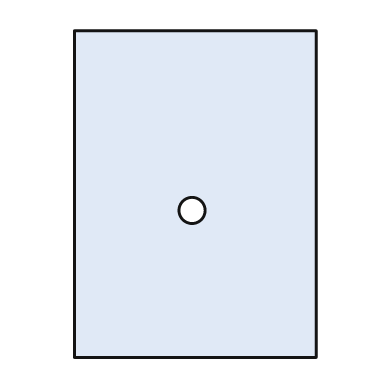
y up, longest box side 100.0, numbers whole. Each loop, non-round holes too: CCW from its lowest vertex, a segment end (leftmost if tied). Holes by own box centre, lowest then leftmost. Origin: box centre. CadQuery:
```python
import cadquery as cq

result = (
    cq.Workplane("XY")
    .moveTo(-37.0, -50.0)
    .lineTo(37.0, -50.0)
    .lineTo(37.0, 50.0)
    .lineTo(-37.0, 50.0)
    .close()
    .moveTo(-1.0, -5.0)
    .circle(4.0)
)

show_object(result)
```